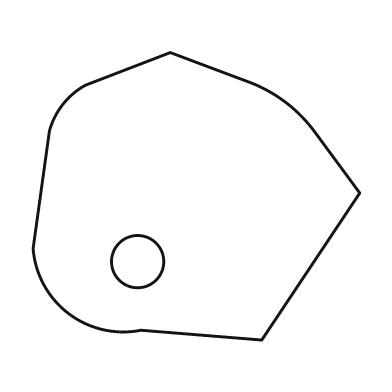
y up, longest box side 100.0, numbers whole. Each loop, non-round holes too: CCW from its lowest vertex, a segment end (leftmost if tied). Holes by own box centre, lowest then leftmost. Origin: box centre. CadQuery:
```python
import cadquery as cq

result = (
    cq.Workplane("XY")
    .moveTo(20.0, -44.0)
    .lineTo(50.0, 1.0)
    .lineTo(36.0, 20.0)
    .threePointArc((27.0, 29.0), (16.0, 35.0))
    .lineTo(-8.0, 44.0)
    .lineTo(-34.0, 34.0)
    .threePointArc((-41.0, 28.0), (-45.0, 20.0))
    .lineTo(-50.0, -16.0)
    .threePointArc((-39.0, -36.0), (-17.0, -41.0))
    .close()
    .moveTo(-18.0, -20.0)
    .circle(8.0)
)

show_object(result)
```